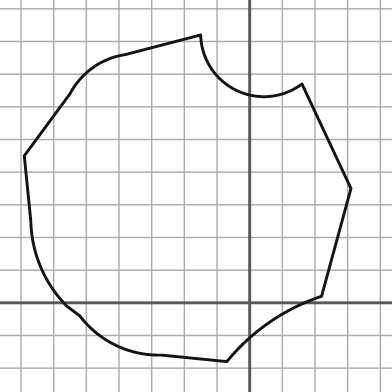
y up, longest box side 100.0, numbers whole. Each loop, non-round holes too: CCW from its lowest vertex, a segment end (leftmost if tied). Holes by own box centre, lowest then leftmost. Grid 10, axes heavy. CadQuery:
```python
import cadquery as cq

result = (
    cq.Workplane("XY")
    .moveTo(-7.0, -18.0)
    .threePointArc((6.0, -6.0), (22.0, 2.0))
    .lineTo(31.0, 35.0)
    .lineTo(16.0, 67.0)
    .threePointArc((-4.0, 65.0), (-15.0, 82.0))
    .lineTo(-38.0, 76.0)
    .threePointArc((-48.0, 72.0), (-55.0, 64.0))
    .lineTo(-69.0, 45.0)
    .lineTo(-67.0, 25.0)
    .threePointArc((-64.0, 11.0), (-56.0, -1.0))
    .lineTo(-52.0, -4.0)
    .threePointArc((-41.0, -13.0), (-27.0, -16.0))
    .close()
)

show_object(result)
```